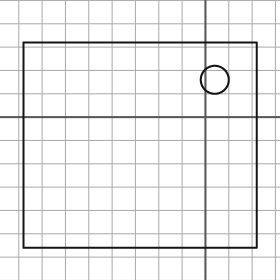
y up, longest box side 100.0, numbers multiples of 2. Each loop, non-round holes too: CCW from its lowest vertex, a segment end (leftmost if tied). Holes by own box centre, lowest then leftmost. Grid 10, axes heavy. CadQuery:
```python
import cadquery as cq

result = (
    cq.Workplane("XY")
    .moveTo(-78.0, -56.0)
    .lineTo(22.0, -56.0)
    .lineTo(22.0, 32.0)
    .lineTo(-78.0, 32.0)
    .close()
    .moveTo(4.0, 16.0)
    .circle(6.0)
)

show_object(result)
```